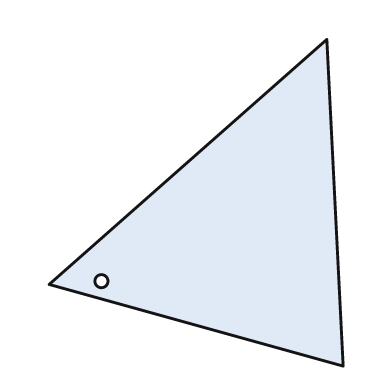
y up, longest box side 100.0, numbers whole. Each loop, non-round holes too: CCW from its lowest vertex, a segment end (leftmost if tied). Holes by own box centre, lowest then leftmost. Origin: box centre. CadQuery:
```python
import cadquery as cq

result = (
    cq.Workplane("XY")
    .moveTo(45.0, -50.0)
    .lineTo(40.0, 50.0)
    .lineTo(-45.0, -25.0)
    .close()
    .moveTo(-29.0, -24.0)
    .circle(2.0)
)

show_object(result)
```